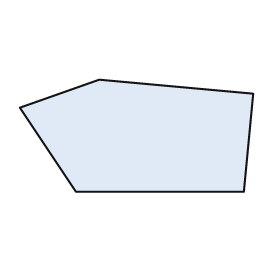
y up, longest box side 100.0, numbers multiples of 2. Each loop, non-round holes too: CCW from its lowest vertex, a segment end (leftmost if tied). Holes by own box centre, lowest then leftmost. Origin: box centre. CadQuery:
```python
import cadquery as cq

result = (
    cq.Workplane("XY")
    .moveTo(-26.0, -24.0)
    .lineTo(46.0, -24.0)
    .lineTo(50.0, 18.0)
    .lineTo(-16.0, 24.0)
    .lineTo(-50.0, 12.0)
    .close()
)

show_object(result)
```